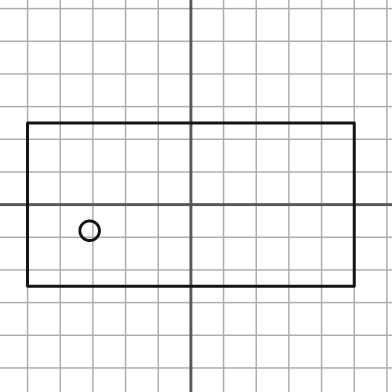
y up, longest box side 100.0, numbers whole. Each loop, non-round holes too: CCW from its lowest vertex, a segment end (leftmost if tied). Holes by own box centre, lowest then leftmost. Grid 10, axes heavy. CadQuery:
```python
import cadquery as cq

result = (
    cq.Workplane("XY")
    .moveTo(-50.0, -25.0)
    .lineTo(50.0, -25.0)
    .lineTo(50.0, 25.0)
    .lineTo(-50.0, 25.0)
    .close()
    .moveTo(-31.0, -8.0)
    .circle(3.0)
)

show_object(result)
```